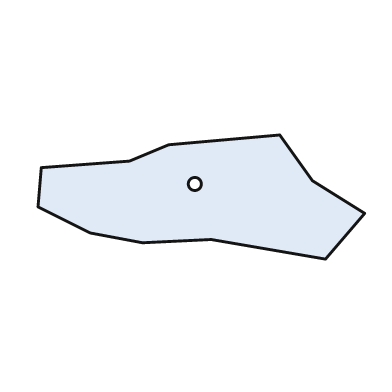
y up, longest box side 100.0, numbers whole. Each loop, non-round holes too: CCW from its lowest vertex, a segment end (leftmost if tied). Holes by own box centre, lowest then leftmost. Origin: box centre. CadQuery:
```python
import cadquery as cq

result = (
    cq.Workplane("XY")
    .moveTo(38.0, -19.0)
    .lineTo(50.0, -5.0)
    .lineTo(34.0, 5.0)
    .lineTo(24.0, 19.0)
    .lineTo(-10.0, 16.0)
    .lineTo(-22.0, 11.0)
    .lineTo(-49.0, 9.0)
    .lineTo(-50.0, -3.0)
    .lineTo(-34.0, -11.0)
    .lineTo(-18.0, -14.0)
    .lineTo(3.0, -13.0)
    .close()
    .moveTo(-2.0, 4.0)
    .circle(2.0)
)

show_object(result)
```